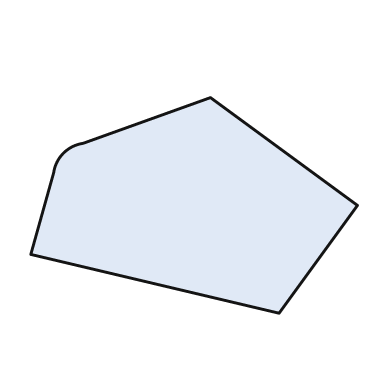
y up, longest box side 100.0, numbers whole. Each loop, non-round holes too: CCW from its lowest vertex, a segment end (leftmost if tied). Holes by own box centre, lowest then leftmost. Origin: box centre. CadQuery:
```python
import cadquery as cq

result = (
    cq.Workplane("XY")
    .moveTo(26.0, -33.0)
    .lineTo(50.0, 0.0)
    .lineTo(5.0, 33.0)
    .lineTo(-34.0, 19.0)
    .threePointArc((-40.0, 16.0), (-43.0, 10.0))
    .lineTo(-50.0, -15.0)
    .close()
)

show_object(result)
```